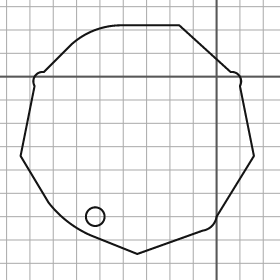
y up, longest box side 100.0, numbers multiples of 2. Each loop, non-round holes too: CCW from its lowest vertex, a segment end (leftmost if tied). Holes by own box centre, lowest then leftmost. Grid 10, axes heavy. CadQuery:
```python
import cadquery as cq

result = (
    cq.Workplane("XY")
    .moveTo(-34.0, -76.0)
    .lineTo(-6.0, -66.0)
    .threePointArc((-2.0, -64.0), (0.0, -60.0))
    .lineTo(16.0, -34.0)
    .lineTo(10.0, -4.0)
    .threePointArc((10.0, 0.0), (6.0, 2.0))
    .lineTo(-16.0, 22.0)
    .lineTo(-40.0, 22.0)
    .threePointArc((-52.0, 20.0), (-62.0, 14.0))
    .lineTo(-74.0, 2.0)
    .threePointArc((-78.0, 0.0), (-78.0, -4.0))
    .lineTo(-84.0, -34.0)
    .lineTo(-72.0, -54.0)
    .threePointArc((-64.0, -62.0), (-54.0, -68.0))
    .close()
    .moveTo(-52.0, -60.0)
    .circle(4.0)
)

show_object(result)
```